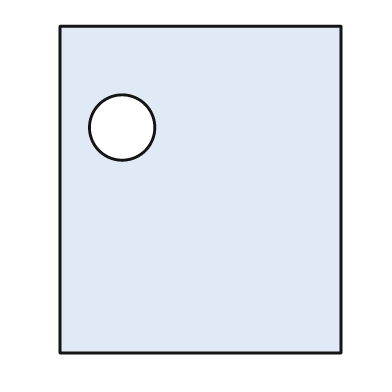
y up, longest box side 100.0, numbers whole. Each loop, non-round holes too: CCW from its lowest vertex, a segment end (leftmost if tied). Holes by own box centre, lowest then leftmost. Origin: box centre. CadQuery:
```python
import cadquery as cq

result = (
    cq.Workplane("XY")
    .moveTo(-43.0, -50.0)
    .lineTo(43.0, -50.0)
    .lineTo(43.0, 50.0)
    .lineTo(-43.0, 50.0)
    .close()
    .moveTo(-24.0, 19.0)
    .circle(10.0)
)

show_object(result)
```